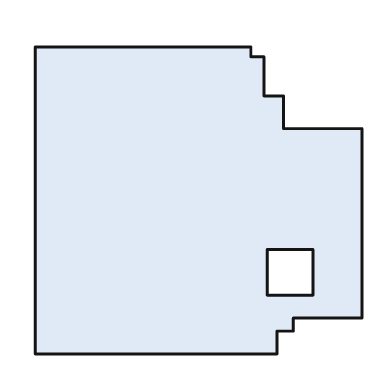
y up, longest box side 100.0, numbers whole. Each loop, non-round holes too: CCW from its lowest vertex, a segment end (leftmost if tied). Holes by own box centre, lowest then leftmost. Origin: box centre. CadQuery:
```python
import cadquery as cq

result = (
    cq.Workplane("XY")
    .moveTo(-50.0, -47.0)
    .lineTo(24.0, -47.0)
    .lineTo(24.0, -40.0)
    .lineTo(29.0, -40.0)
    .lineTo(29.0, -36.0)
    .lineTo(50.0, -36.0)
    .lineTo(50.0, 22.0)
    .lineTo(26.0, 22.0)
    .lineTo(26.0, 32.0)
    .lineTo(20.0, 32.0)
    .lineTo(20.0, 44.0)
    .lineTo(16.0, 44.0)
    .lineTo(16.0, 47.0)
    .lineTo(-50.0, 47.0)
    .close()
    .moveTo(21.0, -29.0)
    .lineTo(35.0, -29.0)
    .lineTo(35.0, -15.0)
    .lineTo(21.0, -15.0)
    .close()
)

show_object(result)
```